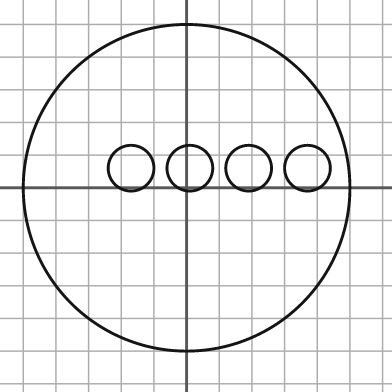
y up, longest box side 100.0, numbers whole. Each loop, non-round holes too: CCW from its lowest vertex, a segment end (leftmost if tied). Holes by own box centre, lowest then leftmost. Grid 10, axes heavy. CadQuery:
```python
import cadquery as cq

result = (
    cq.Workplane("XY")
    .moveTo(0.0, 0.0)
    .circle(50.0)
    .moveTo(-17.0, 6.0)
    .circle(7.0)
    .moveTo(1.0, 6.0)
    .circle(7.0)
    .moveTo(19.0, 6.0)
    .circle(7.0)
    .moveTo(37.0, 6.0)
    .circle(7.0)
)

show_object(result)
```